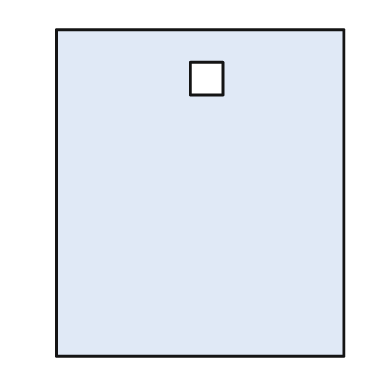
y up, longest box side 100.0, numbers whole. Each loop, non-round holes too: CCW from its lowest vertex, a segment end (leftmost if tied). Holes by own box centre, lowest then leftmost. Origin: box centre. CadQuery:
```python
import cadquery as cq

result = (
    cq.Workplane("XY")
    .moveTo(-44.0, -50.0)
    .lineTo(44.0, -50.0)
    .lineTo(44.0, 50.0)
    .lineTo(-44.0, 50.0)
    .close()
    .moveTo(-3.0, 30.0)
    .lineTo(7.0, 30.0)
    .lineTo(7.0, 40.0)
    .lineTo(-3.0, 40.0)
    .close()
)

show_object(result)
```